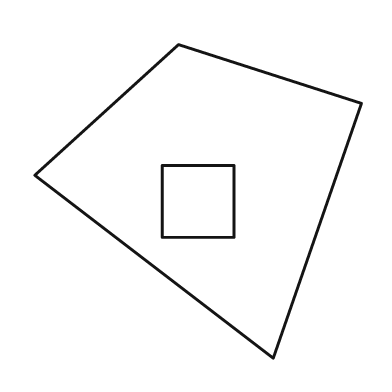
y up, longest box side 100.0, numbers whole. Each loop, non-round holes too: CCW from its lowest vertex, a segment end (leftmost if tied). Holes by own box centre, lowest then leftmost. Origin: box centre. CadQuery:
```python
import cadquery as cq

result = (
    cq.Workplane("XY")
    .moveTo(23.0, -48.0)
    .lineTo(50.0, 30.0)
    .lineTo(-6.0, 48.0)
    .lineTo(-50.0, 8.0)
    .close()
    .moveTo(-11.0, -11.0)
    .lineTo(11.0, -11.0)
    .lineTo(11.0, 11.0)
    .lineTo(-11.0, 11.0)
    .close()
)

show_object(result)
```